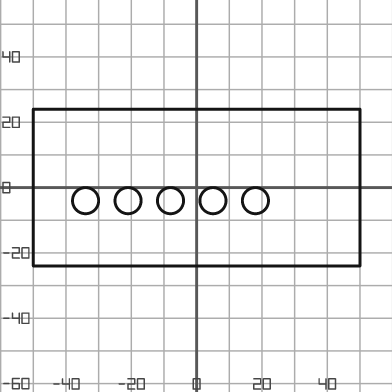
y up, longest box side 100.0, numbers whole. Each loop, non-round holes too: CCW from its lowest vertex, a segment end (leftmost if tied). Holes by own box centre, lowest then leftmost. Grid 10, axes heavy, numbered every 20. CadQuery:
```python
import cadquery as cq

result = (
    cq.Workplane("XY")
    .moveTo(-50.0, -24.0)
    .lineTo(50.0, -24.0)
    .lineTo(50.0, 24.0)
    .lineTo(-50.0, 24.0)
    .close()
    .moveTo(-34.0, -4.0)
    .circle(4.0)
    .moveTo(-21.0, -4.0)
    .circle(4.0)
    .moveTo(-8.0, -4.0)
    .circle(4.0)
    .moveTo(5.0, -4.0)
    .circle(4.0)
    .moveTo(18.0, -4.0)
    .circle(4.0)
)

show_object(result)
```